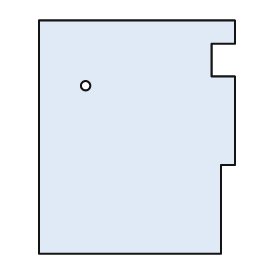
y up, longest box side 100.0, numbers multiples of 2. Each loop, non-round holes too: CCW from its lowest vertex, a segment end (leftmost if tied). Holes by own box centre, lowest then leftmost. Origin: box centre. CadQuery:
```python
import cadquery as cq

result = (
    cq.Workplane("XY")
    .moveTo(-42.0, -50.0)
    .lineTo(36.0, -50.0)
    .lineTo(36.0, -12.0)
    .lineTo(42.0, -12.0)
    .lineTo(42.0, 26.0)
    .lineTo(32.0, 26.0)
    .lineTo(32.0, 40.0)
    .lineTo(42.0, 40.0)
    .lineTo(42.0, 50.0)
    .lineTo(-42.0, 50.0)
    .close()
    .moveTo(-22.0, 22.0)
    .circle(2.0)
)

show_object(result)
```